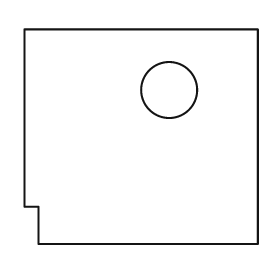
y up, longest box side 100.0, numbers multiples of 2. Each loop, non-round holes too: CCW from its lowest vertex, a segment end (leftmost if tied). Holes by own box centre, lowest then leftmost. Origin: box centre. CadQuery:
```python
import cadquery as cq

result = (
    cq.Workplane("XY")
    .moveTo(-44.0, -46.0)
    .lineTo(50.0, -46.0)
    .lineTo(50.0, 46.0)
    .lineTo(-50.0, 46.0)
    .lineTo(-50.0, -30.0)
    .lineTo(-44.0, -30.0)
    .close()
    .moveTo(12.0, 20.0)
    .circle(12.0)
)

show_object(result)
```